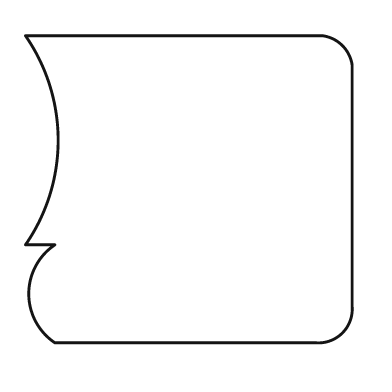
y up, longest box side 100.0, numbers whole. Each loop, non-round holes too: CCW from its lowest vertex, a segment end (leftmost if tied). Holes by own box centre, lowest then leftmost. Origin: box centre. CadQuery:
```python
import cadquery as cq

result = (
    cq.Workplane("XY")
    .moveTo(-41.0, -47.0)
    .lineTo(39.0, -47.0)
    .threePointArc((47.0, -44.0), (50.0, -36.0))
    .lineTo(50.0, 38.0)
    .threePointArc((47.0, 44.0), (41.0, 47.0))
    .lineTo(-50.0, 47.0)
    .threePointArc((-40.0, 15.0), (-50.0, -17.0))
    .lineTo(-41.0, -17.0)
    .threePointArc((-49.0, -32.0), (-41.0, -47.0))
    .close()
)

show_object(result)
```